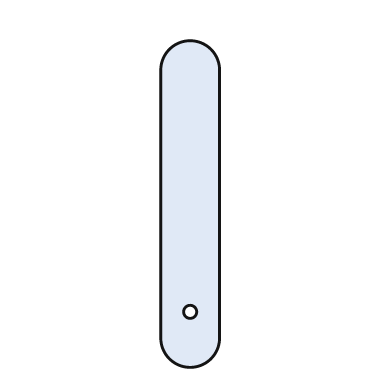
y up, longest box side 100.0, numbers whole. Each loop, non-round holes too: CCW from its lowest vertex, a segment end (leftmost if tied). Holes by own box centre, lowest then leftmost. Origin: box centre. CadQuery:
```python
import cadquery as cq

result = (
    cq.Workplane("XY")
    .moveTo(-9.0, -41.0)
    .threePointArc((0.0, -50.0), (9.0, -41.0))
    .lineTo(9.0, 41.0)
    .threePointArc((0.0, 50.0), (-9.0, 41.0))
    .close()
    .moveTo(0.0, -33.0)
    .circle(2.0)
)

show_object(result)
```